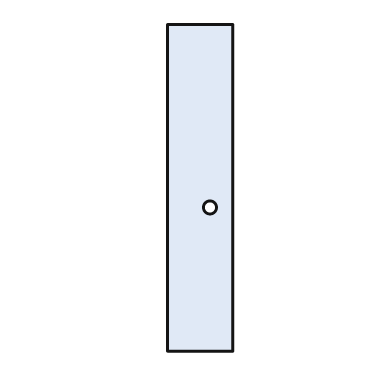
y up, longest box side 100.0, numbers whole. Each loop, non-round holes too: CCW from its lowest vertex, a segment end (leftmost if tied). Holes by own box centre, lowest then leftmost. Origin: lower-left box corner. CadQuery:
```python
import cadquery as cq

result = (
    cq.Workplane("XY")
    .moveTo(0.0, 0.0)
    .lineTo(20.0, 0.0)
    .lineTo(20.0, 100.0)
    .lineTo(0.0, 100.0)
    .close()
    .moveTo(13.0, 44.0)
    .circle(2.0)
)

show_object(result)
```